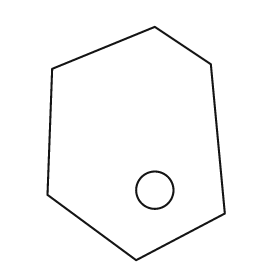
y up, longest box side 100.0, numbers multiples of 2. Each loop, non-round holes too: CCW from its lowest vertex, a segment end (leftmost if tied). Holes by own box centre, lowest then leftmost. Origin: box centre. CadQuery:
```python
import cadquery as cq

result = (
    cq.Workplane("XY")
    .moveTo(0.0, -50.0)
    .lineTo(38.0, -30.0)
    .lineTo(32.0, 34.0)
    .lineTo(8.0, 50.0)
    .lineTo(-36.0, 32.0)
    .lineTo(-38.0, -22.0)
    .close()
    .moveTo(8.0, -20.0)
    .circle(8.0)
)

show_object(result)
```